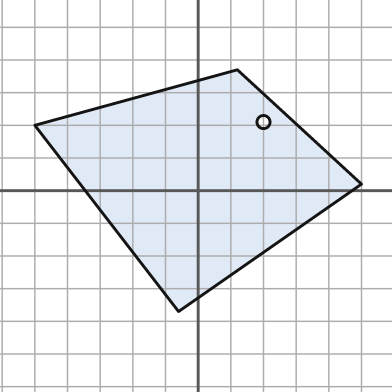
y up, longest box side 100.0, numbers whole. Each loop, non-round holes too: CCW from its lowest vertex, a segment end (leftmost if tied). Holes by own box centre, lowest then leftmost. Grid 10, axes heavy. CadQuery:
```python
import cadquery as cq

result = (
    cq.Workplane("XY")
    .moveTo(-6.0, -37.0)
    .lineTo(50.0, 2.0)
    .lineTo(12.0, 37.0)
    .lineTo(-50.0, 20.0)
    .close()
    .moveTo(20.0, 21.0)
    .circle(2.0)
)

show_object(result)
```